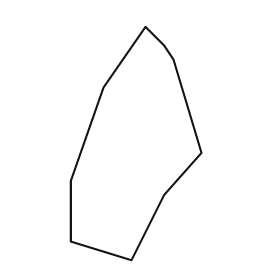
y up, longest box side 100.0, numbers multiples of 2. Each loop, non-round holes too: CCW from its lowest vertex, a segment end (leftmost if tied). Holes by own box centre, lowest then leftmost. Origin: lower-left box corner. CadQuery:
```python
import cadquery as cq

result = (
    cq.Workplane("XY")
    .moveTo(26.0, 0.0)
    .lineTo(40.0, 28.0)
    .lineTo(56.0, 46.0)
    .lineTo(44.0, 86.0)
    .lineTo(40.0, 92.0)
    .lineTo(32.0, 100.0)
    .lineTo(14.0, 74.0)
    .lineTo(0.0, 34.0)
    .lineTo(0.0, 8.0)
    .close()
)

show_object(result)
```